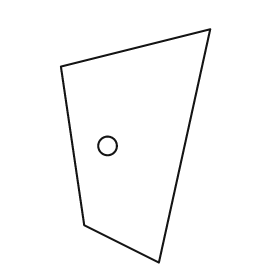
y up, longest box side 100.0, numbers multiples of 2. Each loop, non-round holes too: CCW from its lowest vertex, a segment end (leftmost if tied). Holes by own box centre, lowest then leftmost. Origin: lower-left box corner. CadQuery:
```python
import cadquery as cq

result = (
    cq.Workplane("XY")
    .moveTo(42.0, 0.0)
    .lineTo(64.0, 100.0)
    .lineTo(0.0, 84.0)
    .lineTo(10.0, 16.0)
    .close()
    .moveTo(20.0, 50.0)
    .circle(4.0)
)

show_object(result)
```